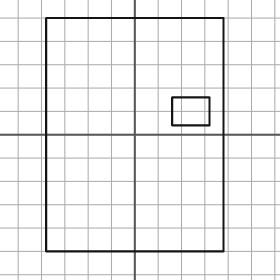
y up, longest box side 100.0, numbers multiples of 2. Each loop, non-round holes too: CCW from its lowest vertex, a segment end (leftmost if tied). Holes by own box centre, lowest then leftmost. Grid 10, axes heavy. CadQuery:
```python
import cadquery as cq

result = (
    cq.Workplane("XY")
    .moveTo(-38.0, -50.0)
    .lineTo(38.0, -50.0)
    .lineTo(38.0, 50.0)
    .lineTo(-38.0, 50.0)
    .close()
    .moveTo(16.0, 4.0)
    .lineTo(32.0, 4.0)
    .lineTo(32.0, 16.0)
    .lineTo(16.0, 16.0)
    .close()
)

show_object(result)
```